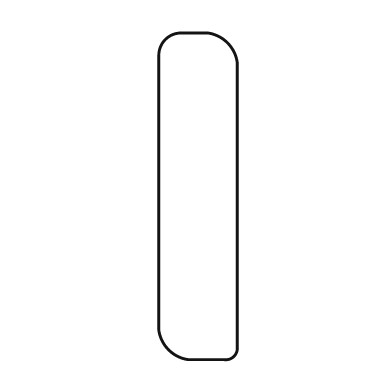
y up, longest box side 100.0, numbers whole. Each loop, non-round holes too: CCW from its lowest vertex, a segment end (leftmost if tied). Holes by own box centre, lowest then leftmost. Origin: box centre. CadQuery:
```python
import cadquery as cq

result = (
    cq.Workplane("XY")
    .moveTo(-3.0, -50.0)
    .lineTo(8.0, -50.0)
    .threePointArc((11.0, -49.0), (12.0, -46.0))
    .lineTo(12.0, 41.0)
    .threePointArc((9.0, 47.0), (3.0, 50.0))
    .lineTo(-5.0, 50.0)
    .threePointArc((-10.0, 48.0), (-12.0, 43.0))
    .lineTo(-12.0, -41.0)
    .threePointArc((-9.0, -47.0), (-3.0, -50.0))
    .close()
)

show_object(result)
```